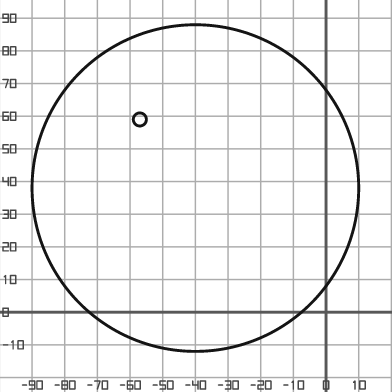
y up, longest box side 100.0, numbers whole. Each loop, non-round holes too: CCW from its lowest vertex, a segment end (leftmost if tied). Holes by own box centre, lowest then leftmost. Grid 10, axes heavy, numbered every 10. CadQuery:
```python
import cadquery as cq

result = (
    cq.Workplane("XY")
    .moveTo(-40.0, 38.0)
    .circle(50.0)
    .moveTo(-57.0, 59.0)
    .circle(2.0)
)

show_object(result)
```